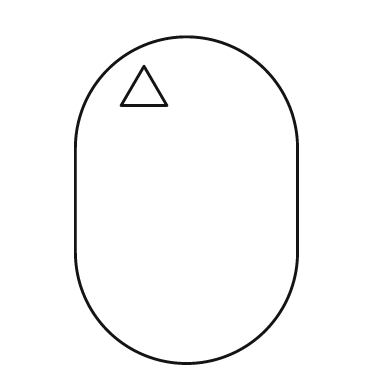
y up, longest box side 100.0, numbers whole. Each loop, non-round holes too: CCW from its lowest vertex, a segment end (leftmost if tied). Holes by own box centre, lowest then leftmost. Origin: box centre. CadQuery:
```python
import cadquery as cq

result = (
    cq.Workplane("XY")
    .moveTo(-34.0, -16.0)
    .threePointArc((0.0, -50.0), (34.0, -16.0))
    .lineTo(34.0, 16.0)
    .threePointArc((0.0, 50.0), (-34.0, 16.0))
    .close()
    .moveTo(-20.0, 29.0)
    .lineTo(-6.0, 29.0)
    .lineTo(-13.0, 41.0)
    .close()
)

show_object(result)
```